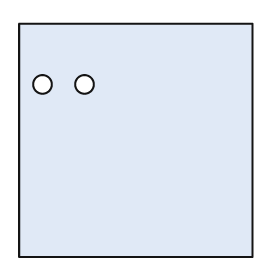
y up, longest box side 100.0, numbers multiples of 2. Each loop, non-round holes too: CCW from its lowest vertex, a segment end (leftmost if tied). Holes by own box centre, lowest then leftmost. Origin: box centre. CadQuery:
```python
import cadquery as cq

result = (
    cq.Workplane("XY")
    .moveTo(-50.0, -50.0)
    .lineTo(50.0, -50.0)
    .lineTo(50.0, 50.0)
    .lineTo(-50.0, 50.0)
    .close()
    .moveTo(-40.0, 24.0)
    .circle(4.0)
    .moveTo(-22.0, 24.0)
    .circle(4.0)
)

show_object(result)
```